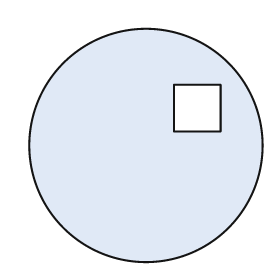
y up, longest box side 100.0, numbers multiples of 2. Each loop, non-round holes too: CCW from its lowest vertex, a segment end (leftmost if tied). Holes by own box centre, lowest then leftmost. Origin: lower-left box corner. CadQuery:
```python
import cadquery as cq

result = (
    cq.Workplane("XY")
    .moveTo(50.0, 50.0)
    .circle(50.0)
    .moveTo(62.0, 56.0)
    .lineTo(82.0, 56.0)
    .lineTo(82.0, 76.0)
    .lineTo(62.0, 76.0)
    .close()
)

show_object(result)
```